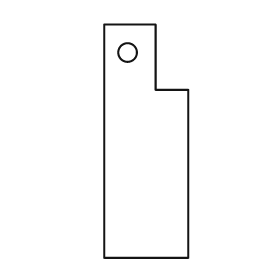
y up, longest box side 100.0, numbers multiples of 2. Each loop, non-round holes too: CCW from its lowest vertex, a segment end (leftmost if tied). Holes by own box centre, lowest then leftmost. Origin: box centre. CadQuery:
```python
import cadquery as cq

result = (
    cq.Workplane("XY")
    .moveTo(-18.0, -50.0)
    .lineTo(18.0, -50.0)
    .lineTo(18.0, 22.0)
    .lineTo(4.0, 22.0)
    .lineTo(4.0, 50.0)
    .lineTo(-18.0, 50.0)
    .close()
    .moveTo(-8.0, 38.0)
    .circle(4.0)
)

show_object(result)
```